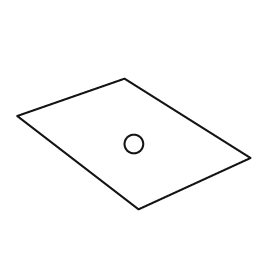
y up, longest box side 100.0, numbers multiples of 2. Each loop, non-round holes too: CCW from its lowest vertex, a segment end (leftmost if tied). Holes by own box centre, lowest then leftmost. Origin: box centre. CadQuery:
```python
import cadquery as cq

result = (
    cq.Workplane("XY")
    .moveTo(2.0, -28.0)
    .lineTo(50.0, -6.0)
    .lineTo(-4.0, 28.0)
    .lineTo(-50.0, 12.0)
    .close()
    .moveTo(0.0, 0.0)
    .circle(4.0)
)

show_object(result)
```